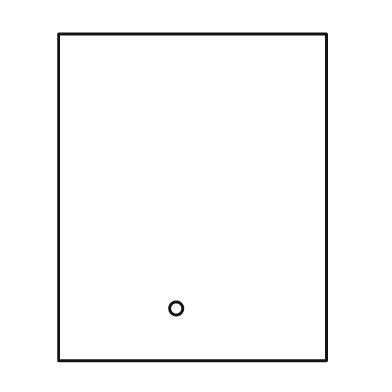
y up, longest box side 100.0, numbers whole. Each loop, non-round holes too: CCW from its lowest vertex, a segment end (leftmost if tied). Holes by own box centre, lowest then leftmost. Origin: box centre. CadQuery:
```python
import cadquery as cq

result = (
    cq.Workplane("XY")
    .moveTo(-41.0, -50.0)
    .lineTo(41.0, -50.0)
    .lineTo(41.0, 50.0)
    .lineTo(-41.0, 50.0)
    .close()
    .moveTo(-5.0, -34.0)
    .circle(2.0)
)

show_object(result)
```